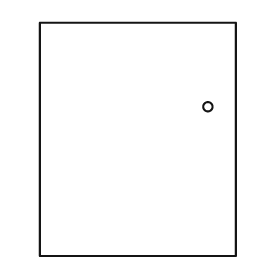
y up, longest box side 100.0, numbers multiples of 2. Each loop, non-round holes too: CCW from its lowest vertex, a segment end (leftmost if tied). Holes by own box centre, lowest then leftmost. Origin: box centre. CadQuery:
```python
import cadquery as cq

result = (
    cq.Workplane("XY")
    .moveTo(-42.0, -50.0)
    .lineTo(42.0, -50.0)
    .lineTo(42.0, 50.0)
    .lineTo(-42.0, 50.0)
    .close()
    .moveTo(30.0, 14.0)
    .circle(2.0)
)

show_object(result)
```